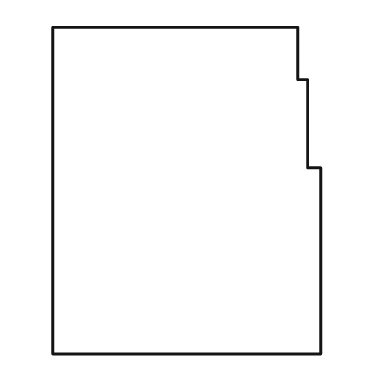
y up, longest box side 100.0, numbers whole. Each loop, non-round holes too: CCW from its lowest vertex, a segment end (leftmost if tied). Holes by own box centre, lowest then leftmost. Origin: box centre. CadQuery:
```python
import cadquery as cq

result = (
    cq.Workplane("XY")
    .moveTo(-41.0, -50.0)
    .lineTo(41.0, -50.0)
    .lineTo(41.0, 7.0)
    .lineTo(37.0, 7.0)
    .lineTo(37.0, 34.0)
    .lineTo(34.0, 34.0)
    .lineTo(34.0, 50.0)
    .lineTo(-41.0, 50.0)
    .close()
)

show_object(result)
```